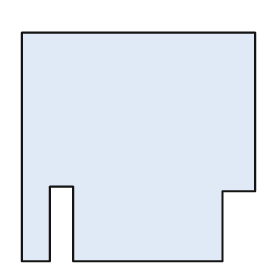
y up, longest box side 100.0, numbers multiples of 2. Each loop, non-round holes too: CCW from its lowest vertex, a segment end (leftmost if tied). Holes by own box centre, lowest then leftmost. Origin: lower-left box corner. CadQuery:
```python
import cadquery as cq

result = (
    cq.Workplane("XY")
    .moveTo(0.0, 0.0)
    .lineTo(12.0, 0.0)
    .lineTo(12.0, 32.0)
    .lineTo(22.0, 32.0)
    .lineTo(22.0, 0.0)
    .lineTo(86.0, 0.0)
    .lineTo(86.0, 30.0)
    .lineTo(100.0, 30.0)
    .lineTo(100.0, 98.0)
    .lineTo(0.0, 98.0)
    .close()
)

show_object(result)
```